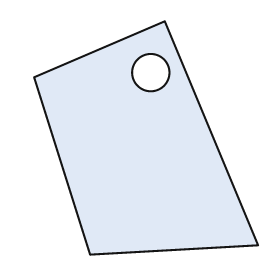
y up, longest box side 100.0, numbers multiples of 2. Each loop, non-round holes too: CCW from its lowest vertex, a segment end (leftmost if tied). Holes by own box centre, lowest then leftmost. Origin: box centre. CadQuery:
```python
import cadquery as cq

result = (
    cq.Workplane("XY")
    .moveTo(-24.0, -50.0)
    .lineTo(48.0, -46.0)
    .lineTo(8.0, 50.0)
    .lineTo(-48.0, 26.0)
    .close()
    .moveTo(2.0, 28.0)
    .circle(8.0)
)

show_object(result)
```